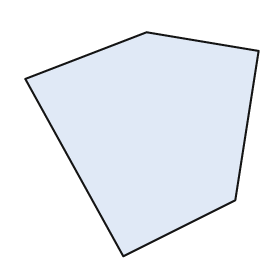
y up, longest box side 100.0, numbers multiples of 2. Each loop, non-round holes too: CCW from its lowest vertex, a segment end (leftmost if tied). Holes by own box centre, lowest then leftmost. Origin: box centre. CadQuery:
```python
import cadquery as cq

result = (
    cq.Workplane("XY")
    .moveTo(-8.0, -48.0)
    .lineTo(40.0, -24.0)
    .lineTo(50.0, 40.0)
    .lineTo(2.0, 48.0)
    .lineTo(-50.0, 28.0)
    .close()
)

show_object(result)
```